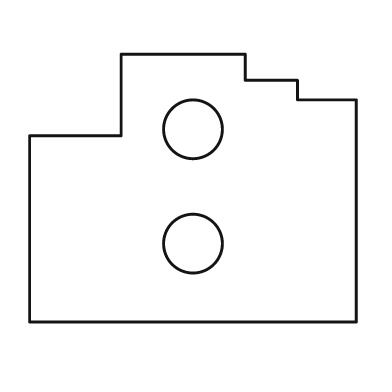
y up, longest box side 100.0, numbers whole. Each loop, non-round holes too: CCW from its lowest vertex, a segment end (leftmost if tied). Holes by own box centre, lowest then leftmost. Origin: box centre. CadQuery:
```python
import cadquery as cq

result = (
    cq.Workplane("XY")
    .moveTo(-50.0, -41.0)
    .lineTo(50.0, -41.0)
    .lineTo(50.0, 27.0)
    .lineTo(32.0, 27.0)
    .lineTo(32.0, 33.0)
    .lineTo(16.0, 33.0)
    .lineTo(16.0, 41.0)
    .lineTo(-22.0, 41.0)
    .lineTo(-22.0, 16.0)
    .lineTo(-50.0, 16.0)
    .close()
    .moveTo(0.0, -17.0)
    .circle(9.0)
    .moveTo(0.0, 18.0)
    .circle(9.0)
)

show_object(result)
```